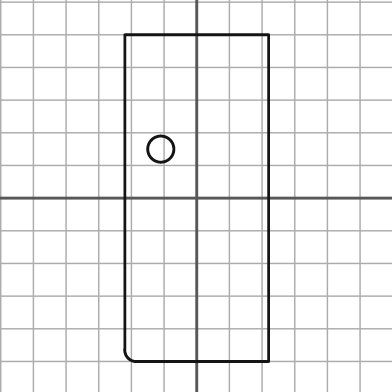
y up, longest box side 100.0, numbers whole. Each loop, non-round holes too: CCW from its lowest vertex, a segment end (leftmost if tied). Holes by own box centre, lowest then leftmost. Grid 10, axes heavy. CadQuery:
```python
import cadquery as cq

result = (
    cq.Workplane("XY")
    .moveTo(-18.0, -50.0)
    .lineTo(22.0, -50.0)
    .lineTo(22.0, 50.0)
    .lineTo(-22.0, 50.0)
    .lineTo(-22.0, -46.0)
    .threePointArc((-21.0, -49.0), (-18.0, -50.0))
    .close()
    .moveTo(-11.0, 15.0)
    .circle(4.0)
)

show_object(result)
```